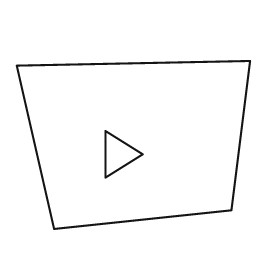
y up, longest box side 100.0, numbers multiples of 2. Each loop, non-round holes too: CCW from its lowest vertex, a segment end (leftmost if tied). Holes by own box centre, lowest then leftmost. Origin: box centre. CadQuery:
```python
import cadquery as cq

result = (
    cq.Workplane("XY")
    .moveTo(-34.0, -36.0)
    .lineTo(42.0, -28.0)
    .lineTo(50.0, 36.0)
    .lineTo(-50.0, 34.0)
    .close()
    .moveTo(-12.0, -14.0)
    .lineTo(4.0, -4.0)
    .lineTo(-12.0, 6.0)
    .close()
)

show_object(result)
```